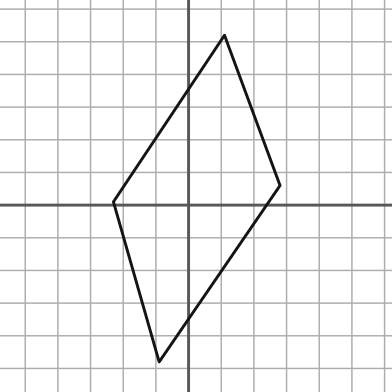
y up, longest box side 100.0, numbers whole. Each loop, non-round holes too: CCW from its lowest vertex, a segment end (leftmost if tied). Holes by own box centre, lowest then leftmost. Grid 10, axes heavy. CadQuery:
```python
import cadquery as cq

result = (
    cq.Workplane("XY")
    .moveTo(-9.0, -48.0)
    .lineTo(28.0, 6.0)
    .lineTo(11.0, 52.0)
    .lineTo(-23.0, 1.0)
    .close()
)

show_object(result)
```